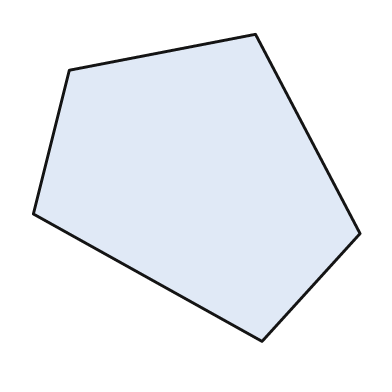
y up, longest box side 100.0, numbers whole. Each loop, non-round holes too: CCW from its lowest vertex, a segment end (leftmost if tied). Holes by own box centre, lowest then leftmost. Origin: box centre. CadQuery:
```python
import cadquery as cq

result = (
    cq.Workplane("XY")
    .moveTo(20.0, -47.0)
    .lineTo(50.0, -14.0)
    .lineTo(18.0, 47.0)
    .lineTo(-39.0, 36.0)
    .lineTo(-50.0, -8.0)
    .close()
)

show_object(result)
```